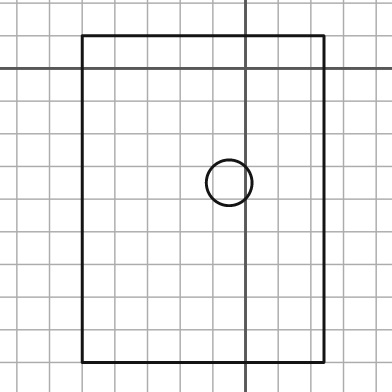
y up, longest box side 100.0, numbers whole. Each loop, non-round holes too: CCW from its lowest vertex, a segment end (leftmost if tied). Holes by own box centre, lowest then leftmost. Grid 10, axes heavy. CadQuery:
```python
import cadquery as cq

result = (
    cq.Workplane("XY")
    .moveTo(-50.0, -90.0)
    .lineTo(24.0, -90.0)
    .lineTo(24.0, 10.0)
    .lineTo(-50.0, 10.0)
    .close()
    .moveTo(-5.0, -35.0)
    .circle(7.0)
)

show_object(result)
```